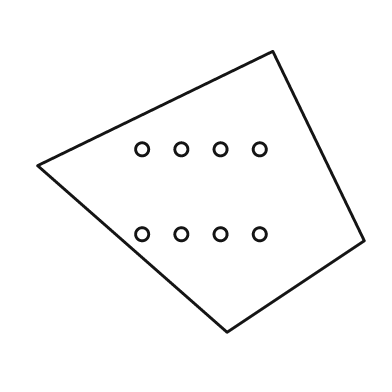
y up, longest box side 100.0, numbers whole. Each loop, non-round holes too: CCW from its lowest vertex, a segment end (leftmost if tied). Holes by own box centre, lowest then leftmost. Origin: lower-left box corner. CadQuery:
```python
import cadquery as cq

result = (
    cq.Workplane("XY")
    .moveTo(58.0, 0.0)
    .lineTo(100.0, 28.0)
    .lineTo(72.0, 86.0)
    .lineTo(0.0, 51.0)
    .close()
    .moveTo(32.0, 30.0)
    .circle(2.0)
    .moveTo(44.0, 30.0)
    .circle(2.0)
    .moveTo(56.0, 30.0)
    .circle(2.0)
    .moveTo(68.0, 30.0)
    .circle(2.0)
    .moveTo(32.0, 56.0)
    .circle(2.0)
    .moveTo(44.0, 56.0)
    .circle(2.0)
    .moveTo(56.0, 56.0)
    .circle(2.0)
    .moveTo(68.0, 56.0)
    .circle(2.0)
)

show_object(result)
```